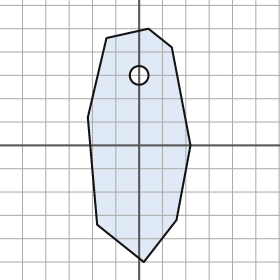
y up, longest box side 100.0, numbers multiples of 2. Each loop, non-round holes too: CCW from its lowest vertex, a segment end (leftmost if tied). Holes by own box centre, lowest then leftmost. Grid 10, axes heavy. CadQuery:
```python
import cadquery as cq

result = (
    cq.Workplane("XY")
    .moveTo(2.0, -50.0)
    .lineTo(16.0, -32.0)
    .lineTo(22.0, 0.0)
    .lineTo(14.0, 42.0)
    .lineTo(4.0, 50.0)
    .lineTo(-14.0, 46.0)
    .lineTo(-22.0, 12.0)
    .lineTo(-18.0, -34.0)
    .close()
    .moveTo(0.0, 30.0)
    .circle(4.0)
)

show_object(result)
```